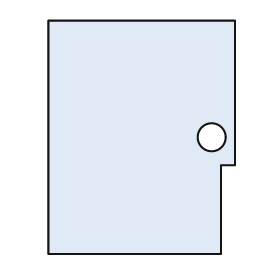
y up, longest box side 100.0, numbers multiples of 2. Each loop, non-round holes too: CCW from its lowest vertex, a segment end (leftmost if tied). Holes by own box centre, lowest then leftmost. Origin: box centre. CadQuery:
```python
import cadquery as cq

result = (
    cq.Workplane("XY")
    .moveTo(-40.0, -50.0)
    .lineTo(34.0, -50.0)
    .lineTo(34.0, -12.0)
    .lineTo(40.0, -12.0)
    .lineTo(40.0, 50.0)
    .lineTo(-40.0, 50.0)
    .close()
    .moveTo(30.0, 0.0)
    .circle(6.0)
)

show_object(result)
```